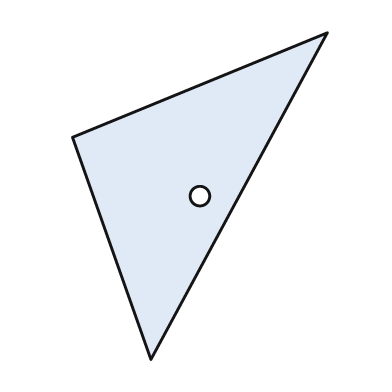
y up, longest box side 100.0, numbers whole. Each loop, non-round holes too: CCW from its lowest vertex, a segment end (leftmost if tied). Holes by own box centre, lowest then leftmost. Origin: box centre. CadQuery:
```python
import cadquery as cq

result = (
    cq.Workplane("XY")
    .moveTo(-15.0, -50.0)
    .lineTo(39.0, 50.0)
    .lineTo(-39.0, 18.0)
    .close()
    .moveTo(0.0, 0.0)
    .circle(3.0)
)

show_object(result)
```